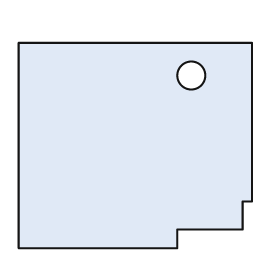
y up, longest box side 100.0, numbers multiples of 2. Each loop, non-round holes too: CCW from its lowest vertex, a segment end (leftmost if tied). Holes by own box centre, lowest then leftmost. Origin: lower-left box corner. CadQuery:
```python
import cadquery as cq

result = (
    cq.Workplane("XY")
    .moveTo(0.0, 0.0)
    .lineTo(68.0, 0.0)
    .lineTo(68.0, 8.0)
    .lineTo(96.0, 8.0)
    .lineTo(96.0, 20.0)
    .lineTo(100.0, 20.0)
    .lineTo(100.0, 88.0)
    .lineTo(0.0, 88.0)
    .close()
    .moveTo(74.0, 74.0)
    .circle(6.0)
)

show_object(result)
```